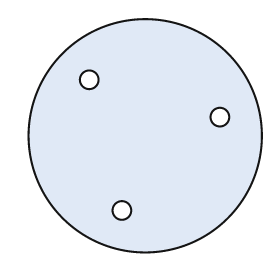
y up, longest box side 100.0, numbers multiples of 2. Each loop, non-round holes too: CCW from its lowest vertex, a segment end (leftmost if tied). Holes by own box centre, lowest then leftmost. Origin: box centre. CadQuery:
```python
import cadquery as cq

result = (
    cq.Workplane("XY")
    .moveTo(0.0, 0.0)
    .circle(50.0)
    .moveTo(-10.0, -32.0)
    .circle(4.0)
    .moveTo(32.0, 8.0)
    .circle(4.0)
    .moveTo(-24.0, 24.0)
    .circle(4.0)
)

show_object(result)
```